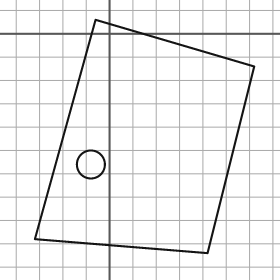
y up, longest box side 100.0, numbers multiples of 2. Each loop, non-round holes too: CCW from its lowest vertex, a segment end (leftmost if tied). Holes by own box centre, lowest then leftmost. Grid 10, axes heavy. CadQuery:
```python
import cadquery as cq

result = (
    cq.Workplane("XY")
    .moveTo(42.0, -94.0)
    .lineTo(62.0, -14.0)
    .lineTo(-6.0, 6.0)
    .lineTo(-32.0, -88.0)
    .close()
    .moveTo(-8.0, -56.0)
    .circle(6.0)
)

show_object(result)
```